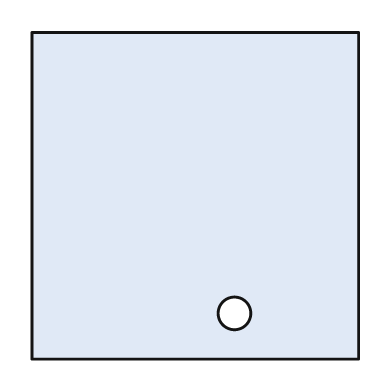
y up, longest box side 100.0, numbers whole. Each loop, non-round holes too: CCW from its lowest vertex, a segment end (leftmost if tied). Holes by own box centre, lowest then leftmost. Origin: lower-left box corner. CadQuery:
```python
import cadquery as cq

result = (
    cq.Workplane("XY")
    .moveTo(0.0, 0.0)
    .lineTo(100.0, 0.0)
    .lineTo(100.0, 100.0)
    .lineTo(0.0, 100.0)
    .close()
    .moveTo(62.0, 14.0)
    .circle(5.0)
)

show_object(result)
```